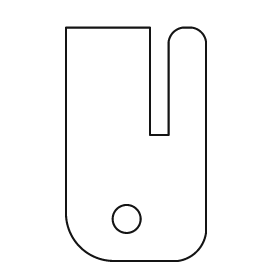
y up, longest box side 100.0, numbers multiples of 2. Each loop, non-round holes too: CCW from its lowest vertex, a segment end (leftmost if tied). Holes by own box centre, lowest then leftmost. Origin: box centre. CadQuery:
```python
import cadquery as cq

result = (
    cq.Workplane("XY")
    .moveTo(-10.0, -50.0)
    .lineTo(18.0, -50.0)
    .threePointArc((26.0, -46.0), (30.0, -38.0))
    .lineTo(30.0, 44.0)
    .threePointArc((28.0, 48.0), (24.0, 50.0))
    .lineTo(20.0, 50.0)
    .threePointArc((16.0, 48.0), (14.0, 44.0))
    .lineTo(14.0, 4.0)
    .lineTo(6.0, 4.0)
    .lineTo(6.0, 50.0)
    .lineTo(-30.0, 50.0)
    .lineTo(-30.0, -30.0)
    .threePointArc((-24.0, -44.0), (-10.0, -50.0))
    .close()
    .moveTo(-4.0, -32.0)
    .circle(6.0)
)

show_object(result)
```